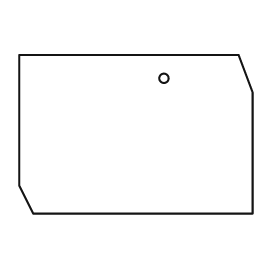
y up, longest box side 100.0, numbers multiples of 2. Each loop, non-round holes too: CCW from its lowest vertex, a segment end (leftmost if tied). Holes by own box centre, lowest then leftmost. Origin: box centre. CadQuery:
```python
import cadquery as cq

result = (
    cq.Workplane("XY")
    .moveTo(-44.0, -34.0)
    .lineTo(50.0, -34.0)
    .lineTo(50.0, 18.0)
    .lineTo(44.0, 34.0)
    .lineTo(-50.0, 34.0)
    .lineTo(-50.0, -22.0)
    .close()
    .moveTo(12.0, 24.0)
    .circle(2.0)
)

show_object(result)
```